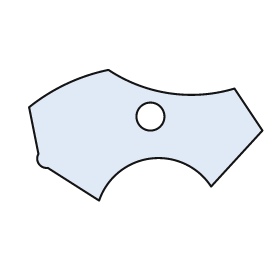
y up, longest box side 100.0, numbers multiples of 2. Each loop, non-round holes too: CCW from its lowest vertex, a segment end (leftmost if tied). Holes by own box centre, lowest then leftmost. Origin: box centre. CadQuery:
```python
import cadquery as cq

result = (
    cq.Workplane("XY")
    .moveTo(-20.0, -28.0)
    .threePointArc((2.0, -10.0), (28.0, -22.0))
    .lineTo(50.0, 2.0)
    .lineTo(38.0, 20.0)
    .threePointArc((10.0, 18.0), (-16.0, 28.0))
    .threePointArc((-34.0, 22.0), (-50.0, 12.0))
    .lineTo(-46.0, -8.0)
    .threePointArc((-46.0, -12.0), (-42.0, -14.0))
    .close()
    .moveTo(2.0, 8.0)
    .circle(6.0)
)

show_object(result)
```